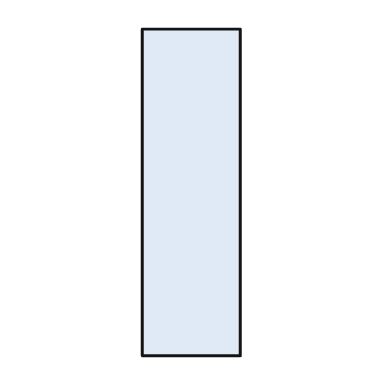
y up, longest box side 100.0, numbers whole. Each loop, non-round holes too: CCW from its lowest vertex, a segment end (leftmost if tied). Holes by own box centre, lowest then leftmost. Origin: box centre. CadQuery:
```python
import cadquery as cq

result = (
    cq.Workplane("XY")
    .moveTo(-15.0, -50.0)
    .lineTo(15.0, -50.0)
    .lineTo(15.0, 50.0)
    .lineTo(-15.0, 50.0)
    .close()
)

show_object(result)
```